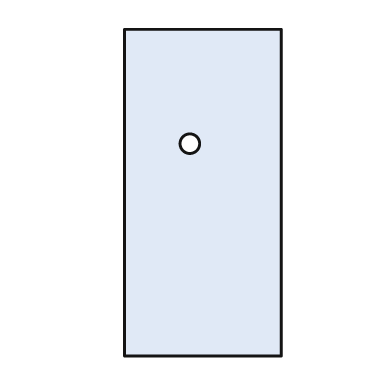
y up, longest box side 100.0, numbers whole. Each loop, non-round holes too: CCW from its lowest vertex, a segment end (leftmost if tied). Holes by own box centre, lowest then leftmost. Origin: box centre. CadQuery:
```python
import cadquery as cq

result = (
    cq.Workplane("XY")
    .moveTo(-24.0, -50.0)
    .lineTo(24.0, -50.0)
    .lineTo(24.0, 50.0)
    .lineTo(-24.0, 50.0)
    .close()
    .moveTo(-4.0, 15.0)
    .circle(3.0)
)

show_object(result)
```